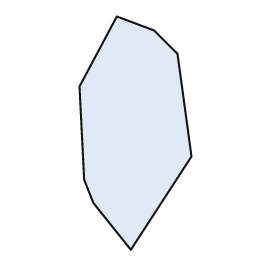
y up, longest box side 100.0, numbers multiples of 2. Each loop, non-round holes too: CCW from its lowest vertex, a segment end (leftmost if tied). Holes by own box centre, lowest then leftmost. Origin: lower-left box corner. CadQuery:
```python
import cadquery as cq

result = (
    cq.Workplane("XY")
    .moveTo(22.0, 0.0)
    .lineTo(48.0, 40.0)
    .lineTo(42.0, 84.0)
    .lineTo(32.0, 94.0)
    .lineTo(16.0, 100.0)
    .lineTo(0.0, 70.0)
    .lineTo(2.0, 30.0)
    .lineTo(6.0, 20.0)
    .close()
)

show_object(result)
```